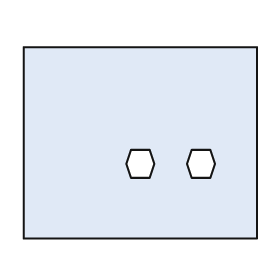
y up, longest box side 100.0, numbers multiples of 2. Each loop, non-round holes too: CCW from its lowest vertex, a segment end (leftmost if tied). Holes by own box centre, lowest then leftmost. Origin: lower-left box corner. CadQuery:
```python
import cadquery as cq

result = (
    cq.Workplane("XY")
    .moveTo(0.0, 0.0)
    .lineTo(100.0, 0.0)
    .lineTo(100.0, 82.0)
    .lineTo(0.0, 82.0)
    .close()
    .moveTo(46.0, 26.0)
    .lineTo(54.0, 26.0)
    .lineTo(56.0, 32.0)
    .lineTo(54.0, 38.0)
    .lineTo(46.0, 38.0)
    .lineTo(44.0, 32.0)
    .close()
    .moveTo(72.0, 26.0)
    .lineTo(80.0, 26.0)
    .lineTo(82.0, 32.0)
    .lineTo(80.0, 38.0)
    .lineTo(72.0, 38.0)
    .lineTo(70.0, 32.0)
    .close()
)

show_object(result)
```